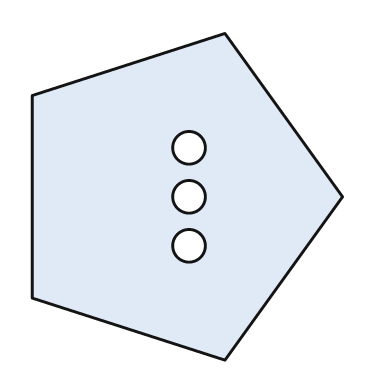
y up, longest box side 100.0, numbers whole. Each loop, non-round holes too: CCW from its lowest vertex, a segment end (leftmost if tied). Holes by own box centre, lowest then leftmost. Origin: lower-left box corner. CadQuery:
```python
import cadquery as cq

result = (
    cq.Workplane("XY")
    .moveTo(59.0, 0.0)
    .lineTo(95.0, 50.0)
    .lineTo(59.0, 100.0)
    .lineTo(0.0, 81.0)
    .lineTo(0.0, 19.0)
    .close()
    .moveTo(48.0, 35.0)
    .circle(5.0)
    .moveTo(48.0, 50.0)
    .circle(5.0)
    .moveTo(48.0, 65.0)
    .circle(5.0)
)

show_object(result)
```